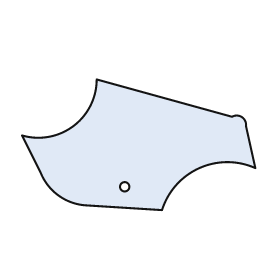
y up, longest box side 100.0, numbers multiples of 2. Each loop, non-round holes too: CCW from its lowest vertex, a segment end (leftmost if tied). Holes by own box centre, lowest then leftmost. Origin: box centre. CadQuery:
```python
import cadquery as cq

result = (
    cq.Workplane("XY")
    .moveTo(10.0, -28.0)
    .threePointArc((26.0, -10.0), (50.0, -10.0))
    .lineTo(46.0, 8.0)
    .threePointArc((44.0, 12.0), (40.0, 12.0))
    .lineTo(-18.0, 28.0)
    .threePointArc((-28.0, 8.0), (-50.0, 4.0))
    .lineTo(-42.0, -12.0)
    .threePointArc((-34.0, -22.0), (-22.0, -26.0))
    .close()
    .moveTo(-6.0, -18.0)
    .circle(2.0)
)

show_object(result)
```